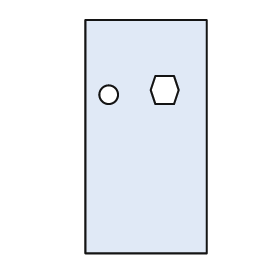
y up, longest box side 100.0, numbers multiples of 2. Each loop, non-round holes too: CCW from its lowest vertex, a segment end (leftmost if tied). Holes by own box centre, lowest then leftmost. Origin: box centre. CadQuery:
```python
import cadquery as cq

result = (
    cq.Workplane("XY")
    .moveTo(-26.0, -50.0)
    .lineTo(26.0, -50.0)
    .lineTo(26.0, 50.0)
    .lineTo(-26.0, 50.0)
    .close()
    .moveTo(-16.0, 18.0)
    .circle(4.0)
    .moveTo(4.0, 14.0)
    .lineTo(12.0, 14.0)
    .lineTo(14.0, 20.0)
    .lineTo(12.0, 26.0)
    .lineTo(4.0, 26.0)
    .lineTo(2.0, 20.0)
    .close()
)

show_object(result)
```